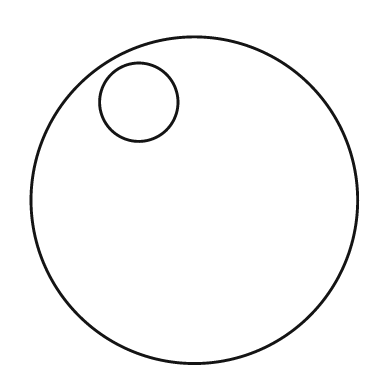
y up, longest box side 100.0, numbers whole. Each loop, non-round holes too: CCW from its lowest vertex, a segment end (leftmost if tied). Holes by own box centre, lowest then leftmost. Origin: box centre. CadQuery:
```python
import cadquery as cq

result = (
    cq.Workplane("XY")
    .moveTo(0.0, 0.0)
    .circle(50.0)
    .moveTo(-17.0, 30.0)
    .circle(12.0)
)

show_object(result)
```